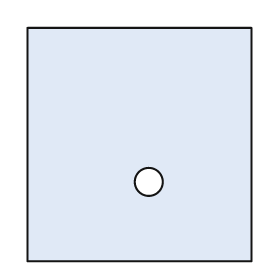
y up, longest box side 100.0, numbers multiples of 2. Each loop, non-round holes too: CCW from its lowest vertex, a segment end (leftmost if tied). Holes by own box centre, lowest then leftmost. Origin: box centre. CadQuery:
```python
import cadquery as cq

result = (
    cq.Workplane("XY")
    .moveTo(-48.0, -50.0)
    .lineTo(48.0, -50.0)
    .lineTo(48.0, 50.0)
    .lineTo(-48.0, 50.0)
    .close()
    .moveTo(4.0, -16.0)
    .circle(6.0)
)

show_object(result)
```